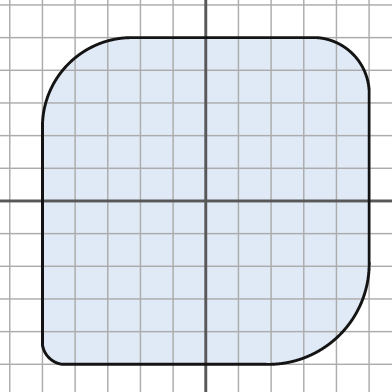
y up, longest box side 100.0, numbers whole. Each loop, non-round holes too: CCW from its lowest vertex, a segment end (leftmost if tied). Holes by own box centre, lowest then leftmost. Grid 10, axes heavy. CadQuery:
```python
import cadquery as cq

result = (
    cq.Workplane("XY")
    .moveTo(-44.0, -50.0)
    .lineTo(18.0, -50.0)
    .threePointArc((41.0, -41.0), (50.0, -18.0))
    .lineTo(50.0, 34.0)
    .threePointArc((45.0, 45.0), (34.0, 50.0))
    .lineTo(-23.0, 50.0)
    .threePointArc((-42.0, 42.0), (-50.0, 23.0))
    .lineTo(-50.0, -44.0)
    .threePointArc((-48.0, -48.0), (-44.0, -50.0))
    .close()
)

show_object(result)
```